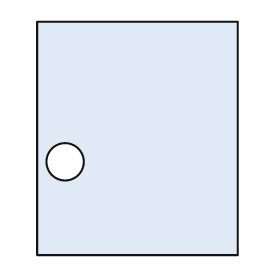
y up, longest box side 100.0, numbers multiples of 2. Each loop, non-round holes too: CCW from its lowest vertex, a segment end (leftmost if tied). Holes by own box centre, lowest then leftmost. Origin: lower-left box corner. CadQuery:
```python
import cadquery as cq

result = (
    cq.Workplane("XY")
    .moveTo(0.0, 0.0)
    .lineTo(86.0, 0.0)
    .lineTo(86.0, 100.0)
    .lineTo(0.0, 100.0)
    .close()
    .moveTo(12.0, 40.0)
    .circle(8.0)
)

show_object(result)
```